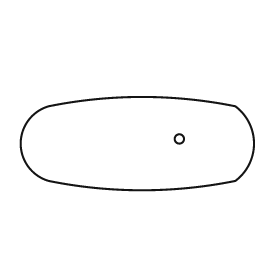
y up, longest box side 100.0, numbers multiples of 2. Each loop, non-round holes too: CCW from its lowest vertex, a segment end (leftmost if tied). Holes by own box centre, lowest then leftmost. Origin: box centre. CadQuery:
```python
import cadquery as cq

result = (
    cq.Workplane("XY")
    .moveTo(-38.0, -16.0)
    .threePointArc((2.0, -20.0), (42.0, -16.0))
    .threePointArc((50.0, 0.0), (42.0, 16.0))
    .threePointArc((2.0, 20.0), (-38.0, 16.0))
    .threePointArc((-50.0, 0.0), (-38.0, -16.0))
    .close()
    .moveTo(18.0, 2.0)
    .circle(2.0)
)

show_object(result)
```